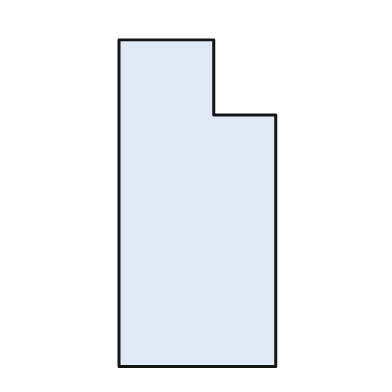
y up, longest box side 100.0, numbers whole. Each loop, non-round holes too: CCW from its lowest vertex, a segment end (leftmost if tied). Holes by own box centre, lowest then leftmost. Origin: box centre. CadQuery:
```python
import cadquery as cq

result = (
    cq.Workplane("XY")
    .moveTo(-24.0, -50.0)
    .lineTo(24.0, -50.0)
    .lineTo(24.0, 27.0)
    .lineTo(5.0, 27.0)
    .lineTo(5.0, 50.0)
    .lineTo(-24.0, 50.0)
    .close()
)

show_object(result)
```